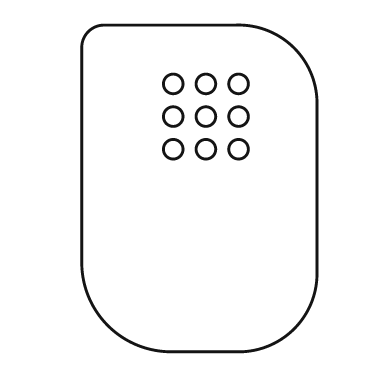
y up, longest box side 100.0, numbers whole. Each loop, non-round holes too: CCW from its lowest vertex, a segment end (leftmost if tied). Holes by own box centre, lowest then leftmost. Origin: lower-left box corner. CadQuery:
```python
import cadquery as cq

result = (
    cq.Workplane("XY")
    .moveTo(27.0, 0.0)
    .lineTo(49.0, 0.0)
    .threePointArc((65.0, 7.0), (72.0, 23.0))
    .lineTo(72.0, 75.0)
    .threePointArc((65.0, 93.0), (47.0, 100.0))
    .lineTo(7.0, 100.0)
    .threePointArc((2.0, 98.0), (0.0, 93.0))
    .lineTo(0.0, 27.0)
    .threePointArc((8.0, 8.0), (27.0, 0.0))
    .close()
    .moveTo(28.0, 62.0)
    .circle(3.0)
    .moveTo(38.0, 62.0)
    .circle(3.0)
    .moveTo(48.0, 62.0)
    .circle(3.0)
    .moveTo(28.0, 72.0)
    .circle(3.0)
    .moveTo(38.0, 72.0)
    .circle(3.0)
    .moveTo(48.0, 72.0)
    .circle(3.0)
    .moveTo(28.0, 82.0)
    .circle(3.0)
    .moveTo(38.0, 82.0)
    .circle(3.0)
    .moveTo(48.0, 82.0)
    .circle(3.0)
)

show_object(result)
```